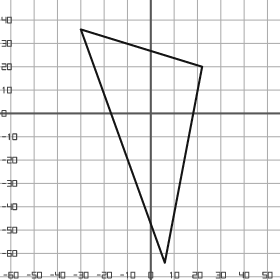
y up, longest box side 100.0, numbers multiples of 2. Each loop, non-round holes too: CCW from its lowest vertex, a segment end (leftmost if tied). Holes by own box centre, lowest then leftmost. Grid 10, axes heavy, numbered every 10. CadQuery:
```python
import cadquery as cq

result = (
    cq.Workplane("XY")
    .moveTo(6.0, -64.0)
    .lineTo(22.0, 20.0)
    .lineTo(-30.0, 36.0)
    .close()
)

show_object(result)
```